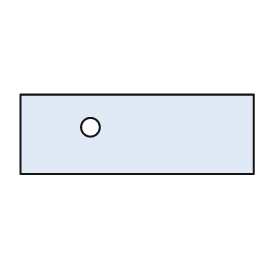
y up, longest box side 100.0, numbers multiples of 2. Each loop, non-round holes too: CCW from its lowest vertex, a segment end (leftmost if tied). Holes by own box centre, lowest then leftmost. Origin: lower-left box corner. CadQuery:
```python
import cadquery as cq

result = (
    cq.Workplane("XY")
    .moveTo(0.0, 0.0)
    .lineTo(100.0, 0.0)
    .lineTo(100.0, 34.0)
    .lineTo(0.0, 34.0)
    .close()
    .moveTo(30.0, 20.0)
    .circle(4.0)
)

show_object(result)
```